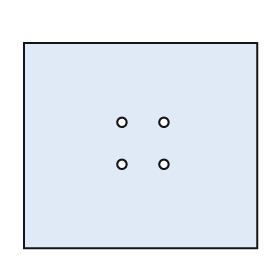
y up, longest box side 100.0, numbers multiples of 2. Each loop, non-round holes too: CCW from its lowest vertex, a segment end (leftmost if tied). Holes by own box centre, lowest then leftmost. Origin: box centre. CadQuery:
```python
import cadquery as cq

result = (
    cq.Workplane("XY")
    .moveTo(-50.0, -44.0)
    .lineTo(50.0, -44.0)
    .lineTo(50.0, 44.0)
    .lineTo(-50.0, 44.0)
    .close()
    .moveTo(-8.0, -8.0)
    .circle(2.0)
    .moveTo(10.0, -8.0)
    .circle(2.0)
    .moveTo(-8.0, 10.0)
    .circle(2.0)
    .moveTo(10.0, 10.0)
    .circle(2.0)
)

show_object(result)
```